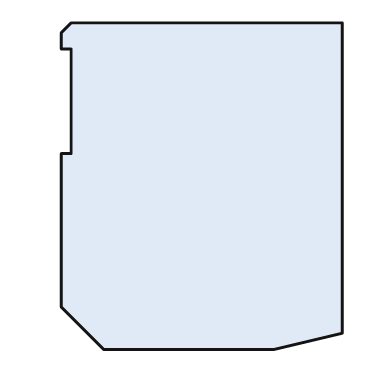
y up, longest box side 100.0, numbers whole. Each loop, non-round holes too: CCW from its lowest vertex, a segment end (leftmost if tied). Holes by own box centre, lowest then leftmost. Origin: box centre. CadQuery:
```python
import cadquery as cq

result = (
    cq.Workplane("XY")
    .moveTo(-30.0, -50.0)
    .lineTo(22.0, -50.0)
    .lineTo(43.0, -45.0)
    .lineTo(43.0, 50.0)
    .lineTo(-40.0, 50.0)
    .lineTo(-43.0, 47.0)
    .lineTo(-43.0, 42.0)
    .lineTo(-40.0, 42.0)
    .lineTo(-40.0, 10.0)
    .lineTo(-43.0, 10.0)
    .lineTo(-43.0, -37.0)
    .close()
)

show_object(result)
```